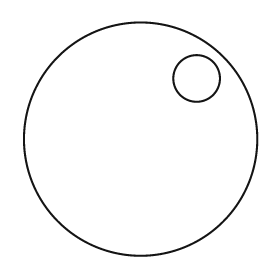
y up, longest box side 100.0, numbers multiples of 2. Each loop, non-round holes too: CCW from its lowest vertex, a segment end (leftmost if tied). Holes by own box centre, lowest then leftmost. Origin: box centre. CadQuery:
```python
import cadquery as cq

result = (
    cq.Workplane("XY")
    .moveTo(0.0, 0.0)
    .circle(50.0)
    .moveTo(24.0, 26.0)
    .circle(10.0)
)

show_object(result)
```